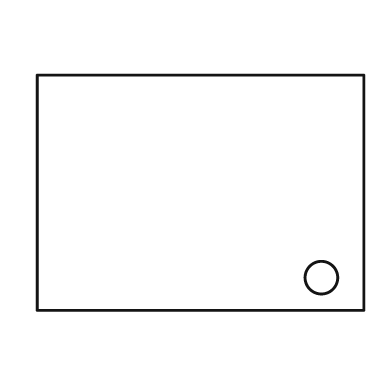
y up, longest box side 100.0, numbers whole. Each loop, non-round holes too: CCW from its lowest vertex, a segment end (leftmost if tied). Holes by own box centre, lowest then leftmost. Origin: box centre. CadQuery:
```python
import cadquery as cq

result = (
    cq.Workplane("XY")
    .moveTo(-50.0, -36.0)
    .lineTo(50.0, -36.0)
    .lineTo(50.0, 36.0)
    .lineTo(-50.0, 36.0)
    .close()
    .moveTo(37.0, -26.0)
    .circle(5.0)
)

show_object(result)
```